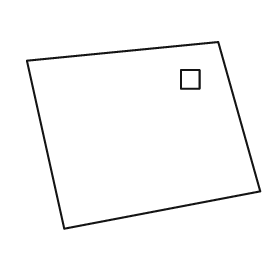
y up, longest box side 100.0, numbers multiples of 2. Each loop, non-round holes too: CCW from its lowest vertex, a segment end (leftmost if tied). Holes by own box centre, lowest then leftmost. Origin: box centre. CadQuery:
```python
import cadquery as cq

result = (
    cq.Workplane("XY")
    .moveTo(-34.0, -40.0)
    .lineTo(50.0, -24.0)
    .lineTo(32.0, 40.0)
    .lineTo(-50.0, 32.0)
    .close()
    .moveTo(16.0, 20.0)
    .lineTo(24.0, 20.0)
    .lineTo(24.0, 28.0)
    .lineTo(16.0, 28.0)
    .close()
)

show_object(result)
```